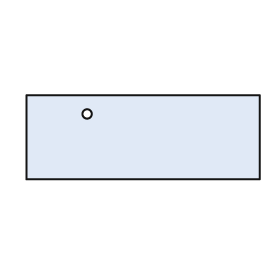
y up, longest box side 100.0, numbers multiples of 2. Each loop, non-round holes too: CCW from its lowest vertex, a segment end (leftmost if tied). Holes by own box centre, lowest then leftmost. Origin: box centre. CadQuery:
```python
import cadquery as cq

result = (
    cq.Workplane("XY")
    .moveTo(-50.0, -18.0)
    .lineTo(50.0, -18.0)
    .lineTo(50.0, 18.0)
    .lineTo(-50.0, 18.0)
    .close()
    .moveTo(-24.0, 10.0)
    .circle(2.0)
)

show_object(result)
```